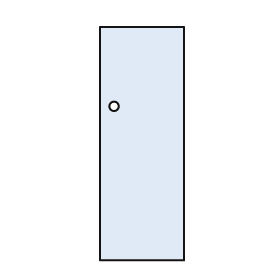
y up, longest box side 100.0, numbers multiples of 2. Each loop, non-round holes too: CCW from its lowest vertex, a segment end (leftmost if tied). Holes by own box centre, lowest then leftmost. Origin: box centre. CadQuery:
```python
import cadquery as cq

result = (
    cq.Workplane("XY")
    .moveTo(-18.0, -50.0)
    .lineTo(18.0, -50.0)
    .lineTo(18.0, 50.0)
    .lineTo(-18.0, 50.0)
    .close()
    .moveTo(-12.0, 16.0)
    .circle(2.0)
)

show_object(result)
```